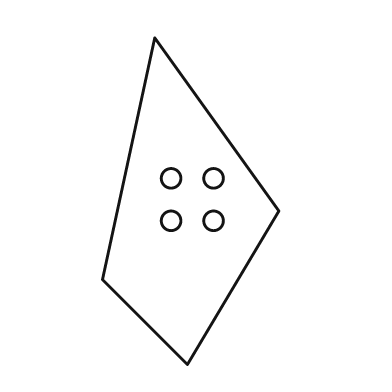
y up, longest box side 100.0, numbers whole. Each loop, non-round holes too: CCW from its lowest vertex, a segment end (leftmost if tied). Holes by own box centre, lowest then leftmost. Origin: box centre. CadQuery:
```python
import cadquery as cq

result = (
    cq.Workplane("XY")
    .moveTo(-1.0, -50.0)
    .lineTo(27.0, -3.0)
    .lineTo(-11.0, 50.0)
    .lineTo(-27.0, -24.0)
    .close()
    .moveTo(-6.0, -6.0)
    .circle(3.0)
    .moveTo(7.0, -6.0)
    .circle(3.0)
    .moveTo(-6.0, 7.0)
    .circle(3.0)
    .moveTo(7.0, 7.0)
    .circle(3.0)
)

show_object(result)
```